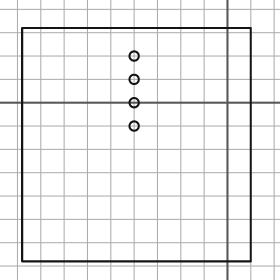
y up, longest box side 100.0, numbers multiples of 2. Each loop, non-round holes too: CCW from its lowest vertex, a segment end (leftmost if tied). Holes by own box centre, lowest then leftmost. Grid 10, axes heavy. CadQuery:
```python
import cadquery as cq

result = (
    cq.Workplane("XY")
    .moveTo(-88.0, -68.0)
    .lineTo(10.0, -68.0)
    .lineTo(10.0, 32.0)
    .lineTo(-88.0, 32.0)
    .close()
    .moveTo(-40.0, -10.0)
    .circle(2.0)
    .moveTo(-40.0, 0.0)
    .circle(2.0)
    .moveTo(-40.0, 10.0)
    .circle(2.0)
    .moveTo(-40.0, 20.0)
    .circle(2.0)
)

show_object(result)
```